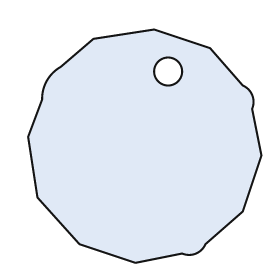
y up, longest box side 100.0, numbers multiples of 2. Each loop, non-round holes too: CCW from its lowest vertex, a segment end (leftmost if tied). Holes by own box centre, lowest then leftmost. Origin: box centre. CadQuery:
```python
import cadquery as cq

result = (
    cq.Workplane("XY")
    .moveTo(-4.0, -50.0)
    .lineTo(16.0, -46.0)
    .threePointArc((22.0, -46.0), (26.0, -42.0))
    .lineTo(42.0, -28.0)
    .lineTo(50.0, -4.0)
    .lineTo(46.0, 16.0)
    .threePointArc((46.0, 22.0), (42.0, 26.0))
    .lineTo(28.0, 42.0)
    .lineTo(4.0, 50.0)
    .lineTo(-22.0, 46.0)
    .lineTo(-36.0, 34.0)
    .threePointArc((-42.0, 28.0), (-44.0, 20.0))
    .lineTo(-50.0, 4.0)
    .lineTo(-46.0, -22.0)
    .lineTo(-28.0, -42.0)
    .close()
    .moveTo(10.0, 32.0)
    .circle(6.0)
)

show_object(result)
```